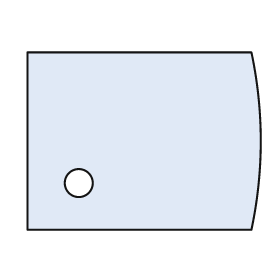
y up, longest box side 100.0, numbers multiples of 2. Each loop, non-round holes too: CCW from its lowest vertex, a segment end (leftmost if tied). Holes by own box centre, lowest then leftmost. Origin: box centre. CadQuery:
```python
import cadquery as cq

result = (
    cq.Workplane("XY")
    .moveTo(-50.0, -38.0)
    .lineTo(46.0, -38.0)
    .threePointArc((50.0, 0.0), (46.0, 38.0))
    .lineTo(-50.0, 38.0)
    .close()
    .moveTo(-28.0, -18.0)
    .circle(6.0)
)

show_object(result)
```